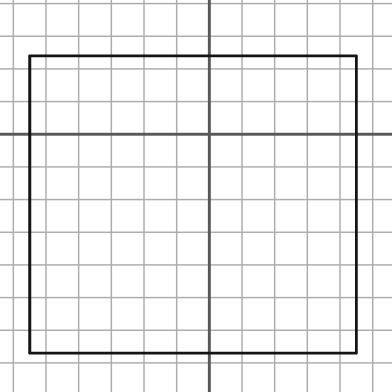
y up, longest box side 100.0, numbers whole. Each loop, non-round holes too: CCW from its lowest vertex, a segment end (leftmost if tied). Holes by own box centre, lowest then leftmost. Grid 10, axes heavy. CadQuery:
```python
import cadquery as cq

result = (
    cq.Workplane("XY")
    .moveTo(-55.0, -67.0)
    .lineTo(45.0, -67.0)
    .lineTo(45.0, 24.0)
    .lineTo(-55.0, 24.0)
    .close()
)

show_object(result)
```